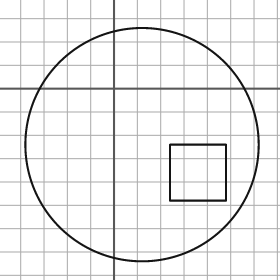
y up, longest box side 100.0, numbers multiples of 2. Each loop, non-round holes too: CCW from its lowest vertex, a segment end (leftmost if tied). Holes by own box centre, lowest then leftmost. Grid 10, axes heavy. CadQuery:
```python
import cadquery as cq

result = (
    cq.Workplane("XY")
    .moveTo(12.0, -24.0)
    .circle(50.0)
    .moveTo(24.0, -48.0)
    .lineTo(48.0, -48.0)
    .lineTo(48.0, -24.0)
    .lineTo(24.0, -24.0)
    .close()
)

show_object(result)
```